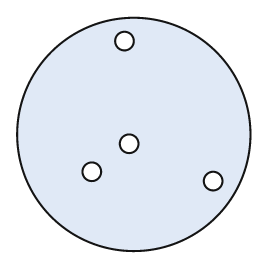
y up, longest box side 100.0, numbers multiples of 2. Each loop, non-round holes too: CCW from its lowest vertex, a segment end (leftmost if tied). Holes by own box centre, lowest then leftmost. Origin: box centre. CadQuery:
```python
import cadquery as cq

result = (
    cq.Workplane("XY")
    .moveTo(0.0, 0.0)
    .circle(50.0)
    .moveTo(34.0, -20.0)
    .circle(4.0)
    .moveTo(-18.0, -16.0)
    .circle(4.0)
    .moveTo(-2.0, -4.0)
    .circle(4.0)
    .moveTo(-4.0, 40.0)
    .circle(4.0)
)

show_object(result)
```